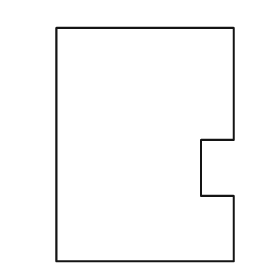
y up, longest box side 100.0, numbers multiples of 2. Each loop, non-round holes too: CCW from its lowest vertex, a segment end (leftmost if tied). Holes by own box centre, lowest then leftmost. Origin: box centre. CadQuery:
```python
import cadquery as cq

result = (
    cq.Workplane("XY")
    .moveTo(-38.0, -50.0)
    .lineTo(38.0, -50.0)
    .lineTo(38.0, -22.0)
    .lineTo(24.0, -22.0)
    .lineTo(24.0, 2.0)
    .lineTo(38.0, 2.0)
    .lineTo(38.0, 50.0)
    .lineTo(-38.0, 50.0)
    .close()
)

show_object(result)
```